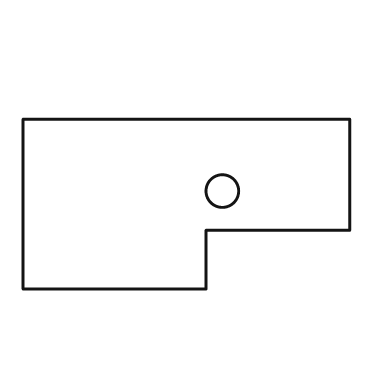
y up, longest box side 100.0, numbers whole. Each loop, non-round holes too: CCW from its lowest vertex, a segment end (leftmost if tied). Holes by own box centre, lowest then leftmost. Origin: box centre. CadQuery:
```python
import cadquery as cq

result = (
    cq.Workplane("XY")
    .moveTo(-50.0, -26.0)
    .lineTo(6.0, -26.0)
    .lineTo(6.0, -8.0)
    .lineTo(50.0, -8.0)
    .lineTo(50.0, 26.0)
    .lineTo(-50.0, 26.0)
    .close()
    .moveTo(11.0, 4.0)
    .circle(5.0)
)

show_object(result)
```